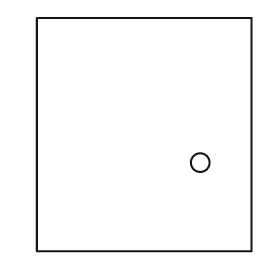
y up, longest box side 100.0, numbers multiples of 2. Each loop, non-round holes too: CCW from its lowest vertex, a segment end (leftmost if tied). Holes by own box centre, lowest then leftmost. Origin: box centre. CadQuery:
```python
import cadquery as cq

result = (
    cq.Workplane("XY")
    .moveTo(-46.0, -50.0)
    .lineTo(46.0, -50.0)
    .lineTo(46.0, 50.0)
    .lineTo(-46.0, 50.0)
    .close()
    .moveTo(24.0, -12.0)
    .circle(4.0)
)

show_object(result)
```